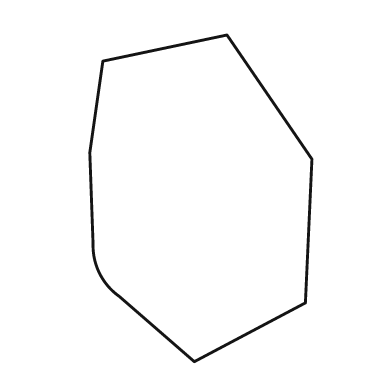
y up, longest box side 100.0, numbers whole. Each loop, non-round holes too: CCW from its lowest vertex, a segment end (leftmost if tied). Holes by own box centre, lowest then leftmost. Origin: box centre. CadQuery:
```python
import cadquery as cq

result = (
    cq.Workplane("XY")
    .moveTo(-2.0, -50.0)
    .lineTo(32.0, -32.0)
    .lineTo(34.0, 12.0)
    .lineTo(8.0, 50.0)
    .lineTo(-30.0, 42.0)
    .lineTo(-34.0, 14.0)
    .lineTo(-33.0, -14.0)
    .threePointArc((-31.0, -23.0), (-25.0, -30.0))
    .close()
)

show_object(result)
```